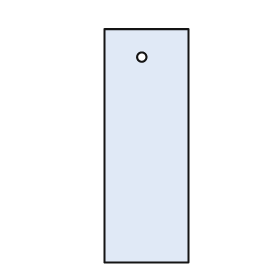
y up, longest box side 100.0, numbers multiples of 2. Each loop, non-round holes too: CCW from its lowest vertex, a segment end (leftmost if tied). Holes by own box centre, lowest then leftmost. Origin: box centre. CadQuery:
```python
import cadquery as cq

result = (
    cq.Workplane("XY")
    .moveTo(-18.0, -50.0)
    .lineTo(18.0, -50.0)
    .lineTo(18.0, 50.0)
    .lineTo(-18.0, 50.0)
    .close()
    .moveTo(-2.0, 38.0)
    .circle(2.0)
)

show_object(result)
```